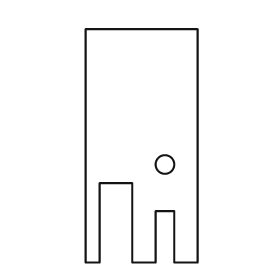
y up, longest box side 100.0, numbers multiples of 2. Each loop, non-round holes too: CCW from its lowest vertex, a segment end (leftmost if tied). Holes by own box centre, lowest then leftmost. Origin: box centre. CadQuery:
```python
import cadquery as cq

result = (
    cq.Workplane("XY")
    .moveTo(-24.0, -50.0)
    .lineTo(-18.0, -50.0)
    .lineTo(-18.0, -16.0)
    .lineTo(-4.0, -16.0)
    .lineTo(-4.0, -50.0)
    .lineTo(6.0, -50.0)
    .lineTo(6.0, -28.0)
    .lineTo(14.0, -28.0)
    .lineTo(14.0, -50.0)
    .lineTo(24.0, -50.0)
    .lineTo(24.0, 50.0)
    .lineTo(-24.0, 50.0)
    .close()
    .moveTo(10.0, -8.0)
    .circle(4.0)
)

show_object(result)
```